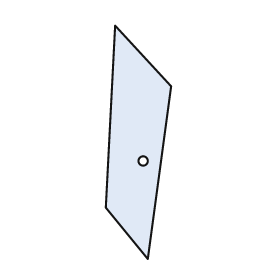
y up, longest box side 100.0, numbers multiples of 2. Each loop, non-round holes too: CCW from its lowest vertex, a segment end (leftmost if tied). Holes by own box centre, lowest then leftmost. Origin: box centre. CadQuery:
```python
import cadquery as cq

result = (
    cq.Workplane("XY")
    .moveTo(4.0, -50.0)
    .lineTo(14.0, 24.0)
    .lineTo(-10.0, 50.0)
    .lineTo(-14.0, -28.0)
    .close()
    .moveTo(2.0, -8.0)
    .circle(2.0)
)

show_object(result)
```